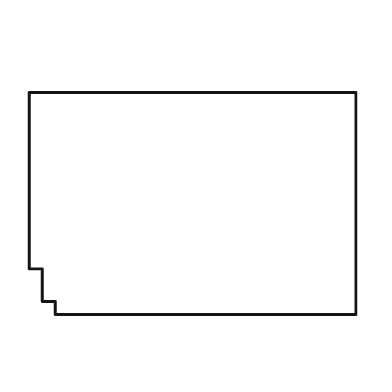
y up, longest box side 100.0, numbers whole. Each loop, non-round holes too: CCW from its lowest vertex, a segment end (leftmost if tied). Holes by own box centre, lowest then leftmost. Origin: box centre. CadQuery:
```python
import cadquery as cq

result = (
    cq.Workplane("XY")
    .moveTo(-42.0, -34.0)
    .lineTo(50.0, -34.0)
    .lineTo(50.0, 34.0)
    .lineTo(-50.0, 34.0)
    .lineTo(-50.0, -20.0)
    .lineTo(-46.0, -20.0)
    .lineTo(-46.0, -30.0)
    .lineTo(-42.0, -30.0)
    .close()
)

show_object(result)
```